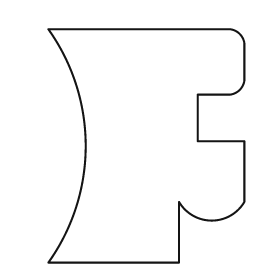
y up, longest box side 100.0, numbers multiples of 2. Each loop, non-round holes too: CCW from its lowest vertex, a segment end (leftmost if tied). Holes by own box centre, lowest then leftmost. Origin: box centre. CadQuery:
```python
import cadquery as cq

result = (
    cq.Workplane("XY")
    .moveTo(-42.0, -50.0)
    .lineTo(14.0, -50.0)
    .lineTo(14.0, -24.0)
    .threePointArc((28.0, -32.0), (42.0, -24.0))
    .lineTo(42.0, 2.0)
    .lineTo(22.0, 2.0)
    .lineTo(22.0, 22.0)
    .lineTo(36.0, 22.0)
    .threePointArc((40.0, 24.0), (42.0, 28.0))
    .lineTo(42.0, 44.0)
    .threePointArc((40.0, 48.0), (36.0, 50.0))
    .lineTo(-42.0, 50.0)
    .threePointArc((-26.0, 0.0), (-42.0, -50.0))
    .close()
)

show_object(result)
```